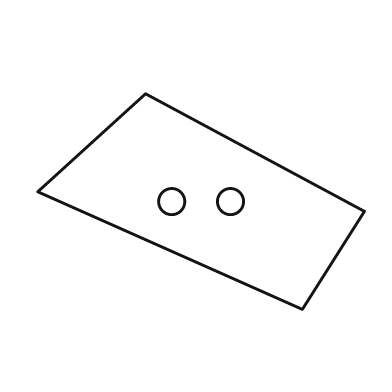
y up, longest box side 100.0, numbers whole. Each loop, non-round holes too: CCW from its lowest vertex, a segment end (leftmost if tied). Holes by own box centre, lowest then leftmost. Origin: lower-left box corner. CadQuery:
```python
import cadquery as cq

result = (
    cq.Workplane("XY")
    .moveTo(81.0, 0.0)
    .lineTo(100.0, 30.0)
    .lineTo(33.0, 66.0)
    .lineTo(0.0, 36.0)
    .close()
    .moveTo(41.0, 33.0)
    .circle(4.0)
    .moveTo(59.0, 33.0)
    .circle(4.0)
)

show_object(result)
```